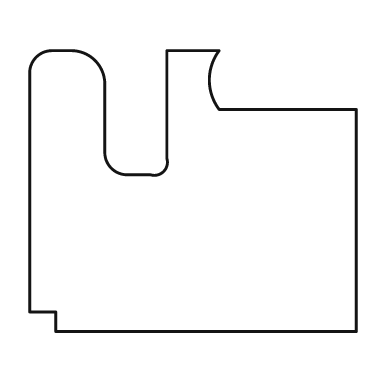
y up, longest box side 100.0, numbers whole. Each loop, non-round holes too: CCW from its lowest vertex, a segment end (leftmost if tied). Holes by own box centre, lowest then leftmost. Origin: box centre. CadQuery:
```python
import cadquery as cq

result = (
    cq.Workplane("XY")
    .moveTo(-42.0, -43.0)
    .lineTo(50.0, -43.0)
    .lineTo(50.0, 25.0)
    .lineTo(8.0, 25.0)
    .threePointArc((5.0, 34.0), (8.0, 43.0))
    .lineTo(-8.0, 43.0)
    .lineTo(-8.0, 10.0)
    .threePointArc((-9.0, 6.0), (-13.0, 5.0))
    .lineTo(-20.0, 5.0)
    .threePointArc((-25.0, 7.0), (-27.0, 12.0))
    .lineTo(-27.0, 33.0)
    .threePointArc((-30.0, 40.0), (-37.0, 43.0))
    .lineTo(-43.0, 43.0)
    .threePointArc((-48.0, 41.0), (-50.0, 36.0))
    .lineTo(-50.0, -37.0)
    .lineTo(-42.0, -37.0)
    .close()
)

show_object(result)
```